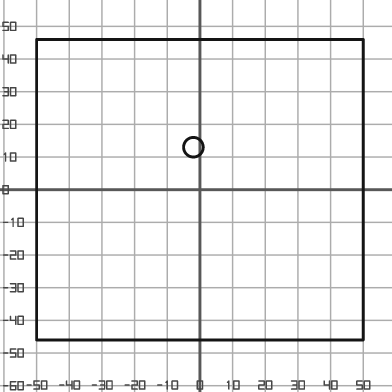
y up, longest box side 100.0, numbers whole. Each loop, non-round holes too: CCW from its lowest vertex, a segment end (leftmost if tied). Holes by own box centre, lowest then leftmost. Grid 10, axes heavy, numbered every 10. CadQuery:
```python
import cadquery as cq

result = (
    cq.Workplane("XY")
    .moveTo(-50.0, -46.0)
    .lineTo(50.0, -46.0)
    .lineTo(50.0, 46.0)
    .lineTo(-50.0, 46.0)
    .close()
    .moveTo(-2.0, 13.0)
    .circle(3.0)
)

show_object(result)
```